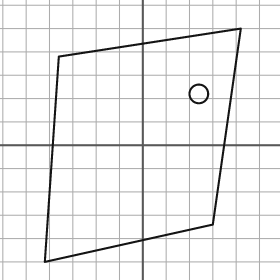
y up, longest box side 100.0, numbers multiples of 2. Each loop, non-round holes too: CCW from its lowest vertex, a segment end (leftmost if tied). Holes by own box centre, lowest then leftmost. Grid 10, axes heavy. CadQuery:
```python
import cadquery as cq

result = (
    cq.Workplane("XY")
    .moveTo(-42.0, -50.0)
    .lineTo(30.0, -34.0)
    .lineTo(42.0, 50.0)
    .lineTo(-36.0, 38.0)
    .close()
    .moveTo(24.0, 22.0)
    .circle(4.0)
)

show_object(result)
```